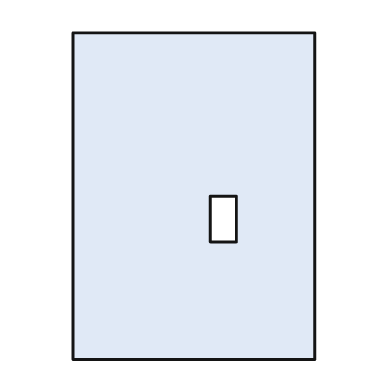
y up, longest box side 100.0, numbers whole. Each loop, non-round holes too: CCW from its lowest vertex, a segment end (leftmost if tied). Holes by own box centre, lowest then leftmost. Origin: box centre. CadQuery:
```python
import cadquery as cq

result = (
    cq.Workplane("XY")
    .moveTo(-37.0, -50.0)
    .lineTo(37.0, -50.0)
    .lineTo(37.0, 50.0)
    .lineTo(-37.0, 50.0)
    .close()
    .moveTo(5.0, -14.0)
    .lineTo(13.0, -14.0)
    .lineTo(13.0, 0.0)
    .lineTo(5.0, 0.0)
    .close()
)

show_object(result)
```